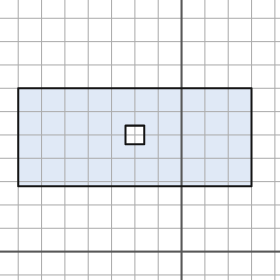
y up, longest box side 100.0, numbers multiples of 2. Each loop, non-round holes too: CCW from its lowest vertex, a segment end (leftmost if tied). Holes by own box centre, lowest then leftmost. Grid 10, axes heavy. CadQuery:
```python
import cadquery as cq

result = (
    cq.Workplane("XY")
    .moveTo(-70.0, 28.0)
    .lineTo(30.0, 28.0)
    .lineTo(30.0, 70.0)
    .lineTo(-70.0, 70.0)
    .close()
    .moveTo(-24.0, 46.0)
    .lineTo(-16.0, 46.0)
    .lineTo(-16.0, 54.0)
    .lineTo(-24.0, 54.0)
    .close()
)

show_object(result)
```